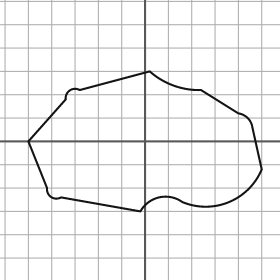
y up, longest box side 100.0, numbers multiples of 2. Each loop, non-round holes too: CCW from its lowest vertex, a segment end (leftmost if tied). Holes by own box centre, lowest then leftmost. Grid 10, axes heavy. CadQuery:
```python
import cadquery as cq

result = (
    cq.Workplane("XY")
    .moveTo(-2.0, -30.0)
    .threePointArc((6.0, -24.0), (16.0, -26.0))
    .threePointArc((36.0, -26.0), (50.0, -12.0))
    .lineTo(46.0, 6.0)
    .threePointArc((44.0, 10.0), (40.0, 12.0))
    .lineTo(24.0, 22.0)
    .threePointArc((12.0, 24.0), (2.0, 30.0))
    .lineTo(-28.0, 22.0)
    .threePointArc((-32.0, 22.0), (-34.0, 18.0))
    .lineTo(-50.0, 0.0)
    .lineTo(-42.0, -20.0)
    .threePointArc((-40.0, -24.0), (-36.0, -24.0))
    .close()
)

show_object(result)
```